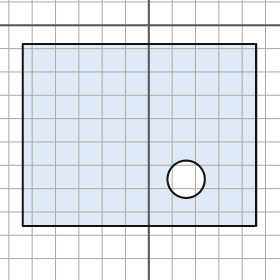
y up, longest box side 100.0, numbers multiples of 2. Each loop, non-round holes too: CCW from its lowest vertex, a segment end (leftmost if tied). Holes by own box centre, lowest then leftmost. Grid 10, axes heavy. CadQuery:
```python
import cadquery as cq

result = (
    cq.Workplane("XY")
    .moveTo(-54.0, -86.0)
    .lineTo(46.0, -86.0)
    .lineTo(46.0, -8.0)
    .lineTo(-54.0, -8.0)
    .close()
    .moveTo(16.0, -66.0)
    .circle(8.0)
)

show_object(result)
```